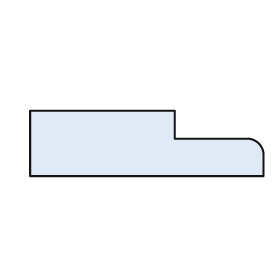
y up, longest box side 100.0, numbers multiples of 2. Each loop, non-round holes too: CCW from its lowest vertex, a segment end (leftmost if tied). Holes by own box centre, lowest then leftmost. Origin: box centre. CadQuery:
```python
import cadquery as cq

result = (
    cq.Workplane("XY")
    .moveTo(-50.0, -14.0)
    .lineTo(50.0, -14.0)
    .lineTo(50.0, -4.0)
    .threePointArc((48.0, 0.0), (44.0, 2.0))
    .lineTo(12.0, 2.0)
    .lineTo(12.0, 14.0)
    .lineTo(-50.0, 14.0)
    .close()
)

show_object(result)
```